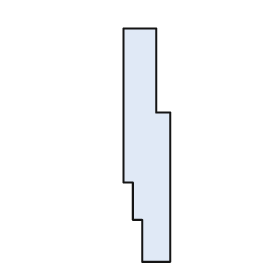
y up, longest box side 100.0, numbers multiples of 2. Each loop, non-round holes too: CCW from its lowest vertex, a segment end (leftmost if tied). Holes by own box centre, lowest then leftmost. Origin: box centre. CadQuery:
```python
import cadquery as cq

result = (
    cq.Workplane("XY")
    .moveTo(-2.0, -50.0)
    .lineTo(10.0, -50.0)
    .lineTo(10.0, 14.0)
    .lineTo(4.0, 14.0)
    .lineTo(4.0, 50.0)
    .lineTo(-10.0, 50.0)
    .lineTo(-10.0, -16.0)
    .lineTo(-6.0, -16.0)
    .lineTo(-6.0, -32.0)
    .lineTo(-2.0, -32.0)
    .close()
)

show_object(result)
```